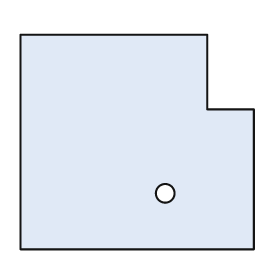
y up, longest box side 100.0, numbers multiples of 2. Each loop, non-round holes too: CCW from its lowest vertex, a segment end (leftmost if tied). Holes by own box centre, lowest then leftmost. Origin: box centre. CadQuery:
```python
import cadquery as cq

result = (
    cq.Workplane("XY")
    .moveTo(-50.0, -46.0)
    .lineTo(50.0, -46.0)
    .lineTo(50.0, 14.0)
    .lineTo(30.0, 14.0)
    .lineTo(30.0, 46.0)
    .lineTo(-50.0, 46.0)
    .close()
    .moveTo(12.0, -22.0)
    .circle(4.0)
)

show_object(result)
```